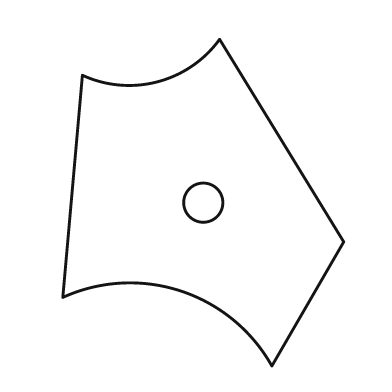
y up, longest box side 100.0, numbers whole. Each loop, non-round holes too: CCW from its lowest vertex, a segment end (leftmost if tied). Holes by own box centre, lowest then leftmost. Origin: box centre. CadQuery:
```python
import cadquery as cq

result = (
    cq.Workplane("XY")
    .moveTo(21.0, -50.0)
    .lineTo(43.0, -12.0)
    .lineTo(5.0, 50.0)
    .threePointArc((-14.0, 37.0), (-37.0, 39.0))
    .lineTo(-43.0, -29.0)
    .threePointArc((-7.0, -27.0), (21.0, -50.0))
    .close()
    .moveTo(0.0, 0.0)
    .circle(6.0)
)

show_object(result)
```